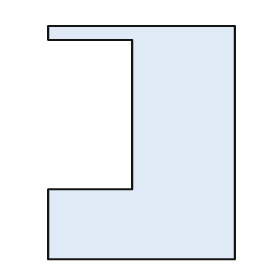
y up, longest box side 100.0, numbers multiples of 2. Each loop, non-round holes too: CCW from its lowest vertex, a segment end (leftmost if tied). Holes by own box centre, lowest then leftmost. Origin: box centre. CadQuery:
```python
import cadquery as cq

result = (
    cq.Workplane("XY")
    .moveTo(-40.0, -50.0)
    .lineTo(40.0, -50.0)
    .lineTo(40.0, 50.0)
    .lineTo(-40.0, 50.0)
    .lineTo(-40.0, 44.0)
    .lineTo(-4.0, 44.0)
    .lineTo(-4.0, -20.0)
    .lineTo(-40.0, -20.0)
    .close()
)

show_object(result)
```